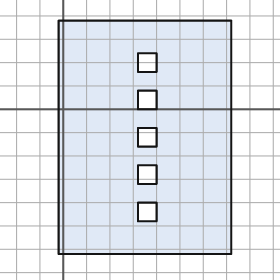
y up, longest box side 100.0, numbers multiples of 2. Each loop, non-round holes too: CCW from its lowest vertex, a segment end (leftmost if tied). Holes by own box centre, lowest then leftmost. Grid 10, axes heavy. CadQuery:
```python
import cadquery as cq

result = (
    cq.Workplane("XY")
    .moveTo(-2.0, -62.0)
    .lineTo(72.0, -62.0)
    .lineTo(72.0, 38.0)
    .lineTo(-2.0, 38.0)
    .close()
    .moveTo(32.0, -48.0)
    .lineTo(40.0, -48.0)
    .lineTo(40.0, -40.0)
    .lineTo(32.0, -40.0)
    .close()
    .moveTo(32.0, -32.0)
    .lineTo(40.0, -32.0)
    .lineTo(40.0, -24.0)
    .lineTo(32.0, -24.0)
    .close()
    .moveTo(32.0, -16.0)
    .lineTo(40.0, -16.0)
    .lineTo(40.0, -8.0)
    .lineTo(32.0, -8.0)
    .close()
    .moveTo(32.0, 0.0)
    .lineTo(40.0, 0.0)
    .lineTo(40.0, 8.0)
    .lineTo(32.0, 8.0)
    .close()
    .moveTo(32.0, 16.0)
    .lineTo(40.0, 16.0)
    .lineTo(40.0, 24.0)
    .lineTo(32.0, 24.0)
    .close()
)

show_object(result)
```